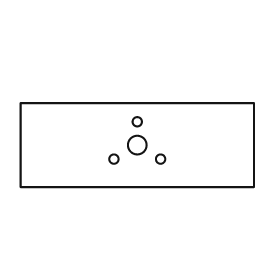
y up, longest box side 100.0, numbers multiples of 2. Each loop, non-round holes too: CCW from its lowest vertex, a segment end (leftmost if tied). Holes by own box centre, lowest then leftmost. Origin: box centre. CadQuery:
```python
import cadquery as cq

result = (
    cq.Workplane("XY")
    .moveTo(-50.0, -18.0)
    .lineTo(50.0, -18.0)
    .lineTo(50.0, 18.0)
    .lineTo(-50.0, 18.0)
    .close()
    .moveTo(-10.0, -6.0)
    .circle(2.0)
    .moveTo(10.0, -6.0)
    .circle(2.0)
    .moveTo(0.0, 0.0)
    .circle(4.0)
    .moveTo(0.0, 10.0)
    .circle(2.0)
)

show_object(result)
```